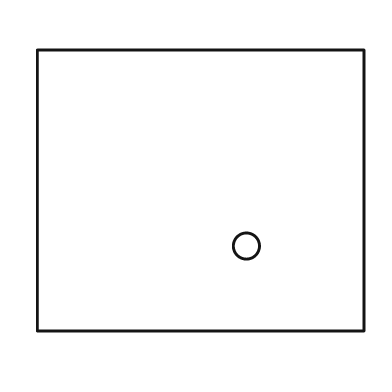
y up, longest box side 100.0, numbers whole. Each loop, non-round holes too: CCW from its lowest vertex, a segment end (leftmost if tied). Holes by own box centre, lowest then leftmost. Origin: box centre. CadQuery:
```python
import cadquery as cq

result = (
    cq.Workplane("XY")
    .moveTo(-50.0, -43.0)
    .lineTo(50.0, -43.0)
    .lineTo(50.0, 43.0)
    .lineTo(-50.0, 43.0)
    .close()
    .moveTo(14.0, -17.0)
    .circle(4.0)
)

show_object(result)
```